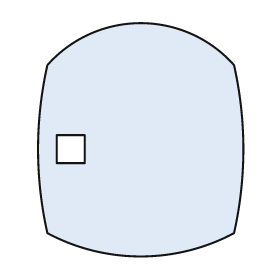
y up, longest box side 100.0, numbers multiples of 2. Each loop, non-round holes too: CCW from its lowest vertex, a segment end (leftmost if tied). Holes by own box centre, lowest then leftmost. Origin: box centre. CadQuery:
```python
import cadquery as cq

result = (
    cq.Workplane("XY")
    .moveTo(-40.0, -40.0)
    .threePointArc((0.0, -50.0), (40.0, -40.0))
    .threePointArc((44.0, -4.0), (40.0, 32.0))
    .threePointArc((0.0, 50.0), (-40.0, 32.0))
    .threePointArc((-44.0, -4.0), (-40.0, -40.0))
    .close()
    .moveTo(-36.0, -10.0)
    .lineTo(-24.0, -10.0)
    .lineTo(-24.0, 2.0)
    .lineTo(-36.0, 2.0)
    .close()
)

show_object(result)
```